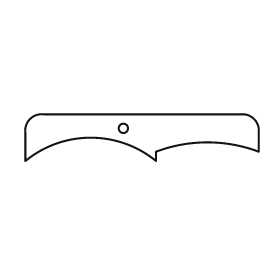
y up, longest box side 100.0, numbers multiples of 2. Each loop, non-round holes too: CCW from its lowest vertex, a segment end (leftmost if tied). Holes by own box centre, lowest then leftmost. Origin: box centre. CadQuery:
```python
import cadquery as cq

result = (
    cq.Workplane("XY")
    .moveTo(-50.0, -10.0)
    .threePointArc((-22.0, 0.0), (6.0, -10.0))
    .lineTo(6.0, -6.0)
    .threePointArc((28.0, -2.0), (50.0, -6.0))
    .lineTo(50.0, 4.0)
    .threePointArc((48.0, 8.0), (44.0, 10.0))
    .lineTo(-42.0, 10.0)
    .threePointArc((-48.0, 8.0), (-50.0, 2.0))
    .close()
    .moveTo(-8.0, 4.0)
    .circle(2.0)
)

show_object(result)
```